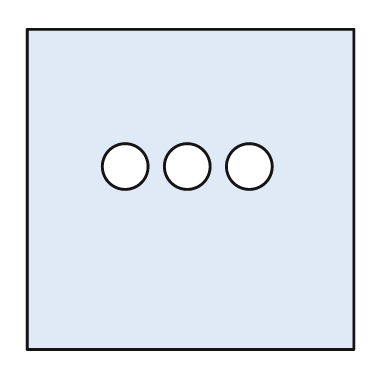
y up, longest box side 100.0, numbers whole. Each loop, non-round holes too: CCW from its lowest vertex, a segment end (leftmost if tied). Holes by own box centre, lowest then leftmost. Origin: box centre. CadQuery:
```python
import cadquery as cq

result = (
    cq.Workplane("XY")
    .moveTo(-50.0, -49.0)
    .lineTo(50.0, -49.0)
    .lineTo(50.0, 49.0)
    .lineTo(-50.0, 49.0)
    .close()
    .moveTo(-20.0, 7.0)
    .circle(7.0)
    .moveTo(-1.0, 7.0)
    .circle(7.0)
    .moveTo(18.0, 7.0)
    .circle(7.0)
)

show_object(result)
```